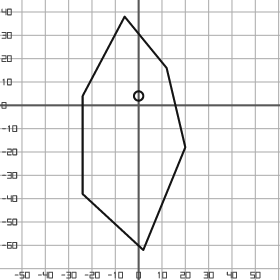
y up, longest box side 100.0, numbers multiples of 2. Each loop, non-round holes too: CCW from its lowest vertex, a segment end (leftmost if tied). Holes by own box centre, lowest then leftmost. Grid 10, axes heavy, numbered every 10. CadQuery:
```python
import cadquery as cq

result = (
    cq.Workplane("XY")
    .moveTo(2.0, -62.0)
    .lineTo(20.0, -18.0)
    .lineTo(12.0, 16.0)
    .lineTo(-6.0, 38.0)
    .lineTo(-24.0, 4.0)
    .lineTo(-24.0, -38.0)
    .close()
    .moveTo(0.0, 4.0)
    .circle(2.0)
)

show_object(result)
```